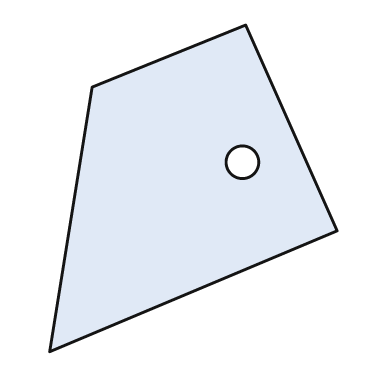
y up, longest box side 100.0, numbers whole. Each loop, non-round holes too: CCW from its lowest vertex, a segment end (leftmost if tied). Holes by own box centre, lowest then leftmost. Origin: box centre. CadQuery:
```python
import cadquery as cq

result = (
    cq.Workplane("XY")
    .moveTo(-44.0, -50.0)
    .lineTo(44.0, -13.0)
    .lineTo(16.0, 50.0)
    .lineTo(-31.0, 31.0)
    .close()
    .moveTo(15.0, 8.0)
    .circle(5.0)
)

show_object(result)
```